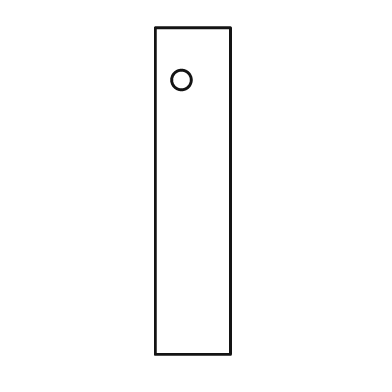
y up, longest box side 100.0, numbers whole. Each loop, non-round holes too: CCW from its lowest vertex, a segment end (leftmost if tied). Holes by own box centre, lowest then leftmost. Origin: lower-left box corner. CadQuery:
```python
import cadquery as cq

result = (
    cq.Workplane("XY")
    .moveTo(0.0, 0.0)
    .lineTo(23.0, 0.0)
    .lineTo(23.0, 100.0)
    .lineTo(0.0, 100.0)
    .close()
    .moveTo(8.0, 84.0)
    .circle(3.0)
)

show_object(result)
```